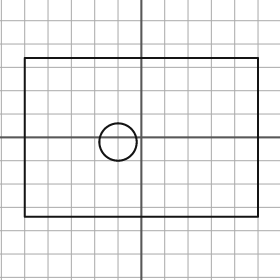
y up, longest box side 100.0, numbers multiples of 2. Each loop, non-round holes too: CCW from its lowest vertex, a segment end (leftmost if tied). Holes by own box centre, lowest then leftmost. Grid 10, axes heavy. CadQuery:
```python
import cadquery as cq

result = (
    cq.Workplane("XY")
    .moveTo(-50.0, -34.0)
    .lineTo(50.0, -34.0)
    .lineTo(50.0, 34.0)
    .lineTo(-50.0, 34.0)
    .close()
    .moveTo(-10.0, -2.0)
    .circle(8.0)
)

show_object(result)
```